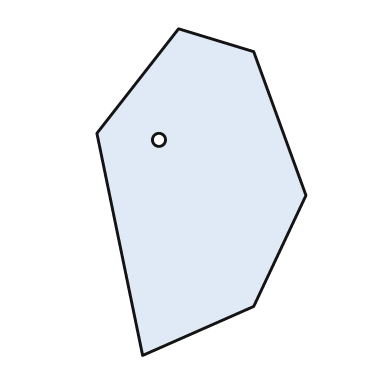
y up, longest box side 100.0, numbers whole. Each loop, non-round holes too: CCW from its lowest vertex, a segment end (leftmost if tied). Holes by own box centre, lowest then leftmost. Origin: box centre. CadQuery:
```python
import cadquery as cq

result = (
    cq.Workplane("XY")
    .moveTo(-18.0, -50.0)
    .lineTo(16.0, -35.0)
    .lineTo(32.0, -1.0)
    .lineTo(16.0, 43.0)
    .lineTo(-7.0, 50.0)
    .lineTo(-32.0, 18.0)
    .close()
    .moveTo(-13.0, 16.0)
    .circle(2.0)
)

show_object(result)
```